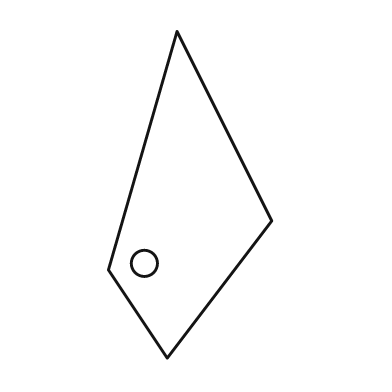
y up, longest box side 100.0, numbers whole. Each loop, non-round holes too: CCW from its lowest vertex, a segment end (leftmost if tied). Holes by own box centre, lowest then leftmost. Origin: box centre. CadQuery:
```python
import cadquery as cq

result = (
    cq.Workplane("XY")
    .moveTo(-7.0, -50.0)
    .lineTo(25.0, -8.0)
    .lineTo(-4.0, 50.0)
    .lineTo(-25.0, -23.0)
    .close()
    .moveTo(-14.0, -21.0)
    .circle(4.0)
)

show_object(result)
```